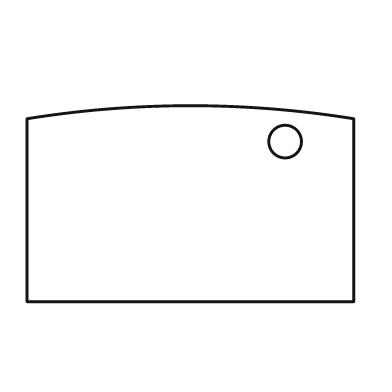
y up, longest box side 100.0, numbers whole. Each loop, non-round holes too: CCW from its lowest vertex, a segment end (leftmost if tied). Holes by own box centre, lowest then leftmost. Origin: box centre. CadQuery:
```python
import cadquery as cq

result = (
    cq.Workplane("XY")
    .moveTo(-50.0, -30.0)
    .lineTo(50.0, -30.0)
    .lineTo(50.0, 26.0)
    .threePointArc((0.0, 30.0), (-50.0, 26.0))
    .close()
    .moveTo(29.0, 19.0)
    .circle(5.0)
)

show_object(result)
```